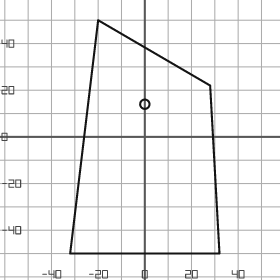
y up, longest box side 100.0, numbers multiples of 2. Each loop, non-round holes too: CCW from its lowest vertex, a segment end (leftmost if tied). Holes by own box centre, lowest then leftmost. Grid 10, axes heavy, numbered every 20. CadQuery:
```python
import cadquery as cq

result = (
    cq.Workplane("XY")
    .moveTo(-32.0, -50.0)
    .lineTo(32.0, -50.0)
    .lineTo(28.0, 22.0)
    .lineTo(-20.0, 50.0)
    .close()
    .moveTo(0.0, 14.0)
    .circle(2.0)
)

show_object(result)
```